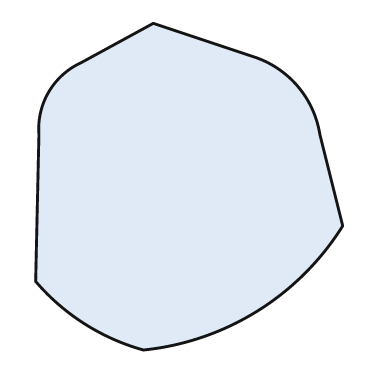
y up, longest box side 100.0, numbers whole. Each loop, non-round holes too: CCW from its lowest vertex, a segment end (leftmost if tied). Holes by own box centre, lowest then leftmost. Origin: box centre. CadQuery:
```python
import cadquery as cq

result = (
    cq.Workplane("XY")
    .moveTo(-14.0, -50.0)
    .threePointArc((21.0, -38.0), (47.0, -12.0))
    .lineTo(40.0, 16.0)
    .threePointArc((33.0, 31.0), (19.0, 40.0))
    .lineTo(-11.0, 50.0)
    .lineTo(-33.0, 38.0)
    .threePointArc((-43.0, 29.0), (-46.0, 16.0))
    .lineTo(-47.0, -29.0)
    .threePointArc((-32.0, -42.0), (-14.0, -50.0))
    .close()
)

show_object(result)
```